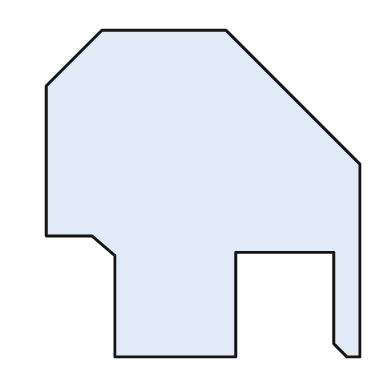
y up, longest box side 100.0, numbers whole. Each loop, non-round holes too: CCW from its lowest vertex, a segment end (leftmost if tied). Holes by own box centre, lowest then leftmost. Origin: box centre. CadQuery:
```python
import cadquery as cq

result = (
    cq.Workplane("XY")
    .moveTo(-27.0, -50.0)
    .lineTo(10.0, -50.0)
    .lineTo(10.0, -18.0)
    .lineTo(40.0, -18.0)
    .lineTo(40.0, -46.0)
    .lineTo(44.0, -50.0)
    .lineTo(48.0, -50.0)
    .lineTo(48.0, 9.0)
    .lineTo(7.0, 50.0)
    .lineTo(-31.0, 50.0)
    .lineTo(-48.0, 33.0)
    .lineTo(-48.0, -13.0)
    .lineTo(-34.0, -13.0)
    .lineTo(-27.0, -19.0)
    .close()
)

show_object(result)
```